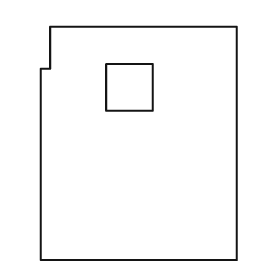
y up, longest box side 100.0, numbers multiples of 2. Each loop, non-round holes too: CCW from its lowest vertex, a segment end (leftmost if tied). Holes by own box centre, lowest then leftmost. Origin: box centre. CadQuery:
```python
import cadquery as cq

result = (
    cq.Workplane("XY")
    .moveTo(-42.0, -50.0)
    .lineTo(42.0, -50.0)
    .lineTo(42.0, 50.0)
    .lineTo(-38.0, 50.0)
    .lineTo(-38.0, 32.0)
    .lineTo(-42.0, 32.0)
    .close()
    .moveTo(-14.0, 14.0)
    .lineTo(6.0, 14.0)
    .lineTo(6.0, 34.0)
    .lineTo(-14.0, 34.0)
    .close()
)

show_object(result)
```